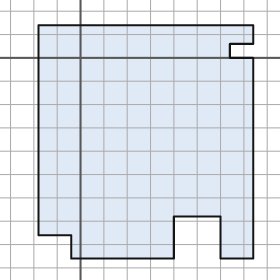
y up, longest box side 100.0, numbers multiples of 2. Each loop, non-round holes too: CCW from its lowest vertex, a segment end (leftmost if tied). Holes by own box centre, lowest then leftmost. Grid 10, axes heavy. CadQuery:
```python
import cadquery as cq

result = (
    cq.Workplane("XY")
    .moveTo(-4.0, -86.0)
    .lineTo(40.0, -86.0)
    .lineTo(40.0, -68.0)
    .lineTo(60.0, -68.0)
    .lineTo(60.0, -86.0)
    .lineTo(74.0, -86.0)
    .lineTo(74.0, 0.0)
    .lineTo(64.0, 0.0)
    .lineTo(64.0, 6.0)
    .lineTo(74.0, 6.0)
    .lineTo(74.0, 14.0)
    .lineTo(-18.0, 14.0)
    .lineTo(-18.0, -76.0)
    .lineTo(-4.0, -76.0)
    .close()
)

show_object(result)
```